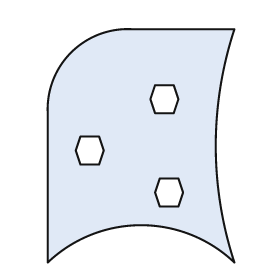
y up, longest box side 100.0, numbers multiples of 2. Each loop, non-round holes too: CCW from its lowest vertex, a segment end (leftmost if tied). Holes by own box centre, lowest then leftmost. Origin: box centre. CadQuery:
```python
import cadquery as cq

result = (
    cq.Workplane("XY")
    .moveTo(-40.0, -50.0)
    .threePointArc((0.0, -34.0), (40.0, -50.0))
    .threePointArc((32.0, 0.0), (40.0, 50.0))
    .lineTo(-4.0, 50.0)
    .threePointArc((-30.0, 40.0), (-40.0, 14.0))
    .close()
    .moveTo(8.0, -26.0)
    .lineTo(16.0, -26.0)
    .lineTo(18.0, -20.0)
    .lineTo(16.0, -14.0)
    .lineTo(8.0, -14.0)
    .lineTo(6.0, -20.0)
    .close()
    .moveTo(-26.0, -8.0)
    .lineTo(-18.0, -8.0)
    .lineTo(-16.0, -2.0)
    .lineTo(-18.0, 4.0)
    .lineTo(-26.0, 4.0)
    .lineTo(-28.0, -2.0)
    .close()
    .moveTo(6.0, 14.0)
    .lineTo(14.0, 14.0)
    .lineTo(16.0, 20.0)
    .lineTo(14.0, 26.0)
    .lineTo(6.0, 26.0)
    .lineTo(4.0, 20.0)
    .close()
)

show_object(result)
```